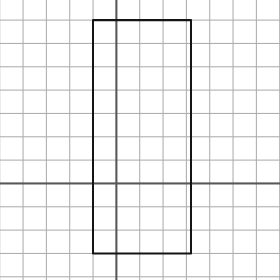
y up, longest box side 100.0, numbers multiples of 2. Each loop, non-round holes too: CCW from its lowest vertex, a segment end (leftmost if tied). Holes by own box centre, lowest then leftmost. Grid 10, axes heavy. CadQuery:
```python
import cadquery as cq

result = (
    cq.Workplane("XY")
    .moveTo(-10.0, -30.0)
    .lineTo(32.0, -30.0)
    .lineTo(32.0, 70.0)
    .lineTo(-10.0, 70.0)
    .close()
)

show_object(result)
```